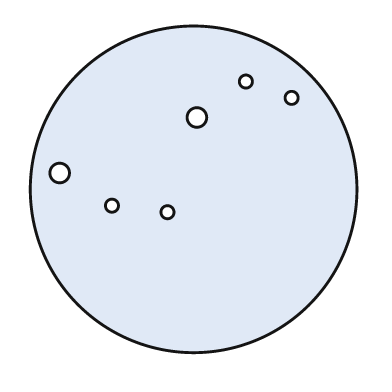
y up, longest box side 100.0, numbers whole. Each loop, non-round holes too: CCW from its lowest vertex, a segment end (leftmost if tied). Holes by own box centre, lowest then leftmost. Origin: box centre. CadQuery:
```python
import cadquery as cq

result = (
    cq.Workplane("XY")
    .moveTo(0.0, 0.0)
    .circle(50.0)
    .moveTo(-8.0, -7.0)
    .circle(2.0)
    .moveTo(-25.0, -5.0)
    .circle(2.0)
    .moveTo(-41.0, 5.0)
    .circle(3.0)
    .moveTo(1.0, 22.0)
    .circle(3.0)
    .moveTo(30.0, 28.0)
    .circle(2.0)
    .moveTo(16.0, 33.0)
    .circle(2.0)
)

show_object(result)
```